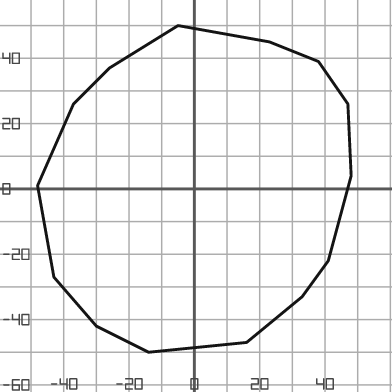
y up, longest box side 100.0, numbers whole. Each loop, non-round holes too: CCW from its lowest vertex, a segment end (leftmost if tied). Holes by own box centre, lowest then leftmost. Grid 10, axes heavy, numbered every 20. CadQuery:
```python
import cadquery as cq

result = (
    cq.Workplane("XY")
    .moveTo(-14.0, -50.0)
    .lineTo(16.0, -47.0)
    .lineTo(33.0, -33.0)
    .lineTo(41.0, -22.0)
    .lineTo(48.0, 4.0)
    .lineTo(47.0, 26.0)
    .lineTo(38.0, 39.0)
    .lineTo(23.0, 45.0)
    .lineTo(-5.0, 50.0)
    .lineTo(-26.0, 37.0)
    .lineTo(-37.0, 26.0)
    .lineTo(-48.0, 1.0)
    .lineTo(-43.0, -27.0)
    .lineTo(-30.0, -42.0)
    .close()
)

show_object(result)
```